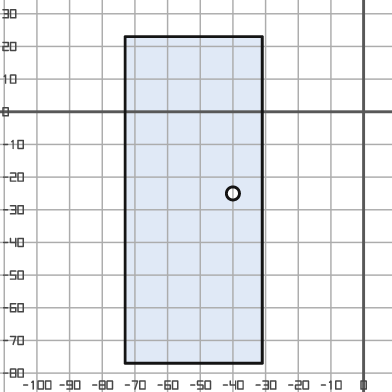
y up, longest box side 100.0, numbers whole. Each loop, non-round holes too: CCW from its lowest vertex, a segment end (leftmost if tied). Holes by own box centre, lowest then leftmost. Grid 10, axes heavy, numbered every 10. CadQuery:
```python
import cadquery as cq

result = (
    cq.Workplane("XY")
    .moveTo(-73.0, -77.0)
    .lineTo(-31.0, -77.0)
    .lineTo(-31.0, 23.0)
    .lineTo(-73.0, 23.0)
    .close()
    .moveTo(-40.0, -25.0)
    .circle(2.0)
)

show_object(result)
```